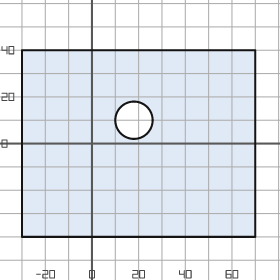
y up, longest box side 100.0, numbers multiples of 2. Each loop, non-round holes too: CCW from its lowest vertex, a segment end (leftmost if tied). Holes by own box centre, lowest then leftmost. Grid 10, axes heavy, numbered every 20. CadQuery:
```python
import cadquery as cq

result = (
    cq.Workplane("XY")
    .moveTo(-30.0, -40.0)
    .lineTo(70.0, -40.0)
    .lineTo(70.0, 40.0)
    .lineTo(-30.0, 40.0)
    .close()
    .moveTo(18.0, 10.0)
    .circle(8.0)
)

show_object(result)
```